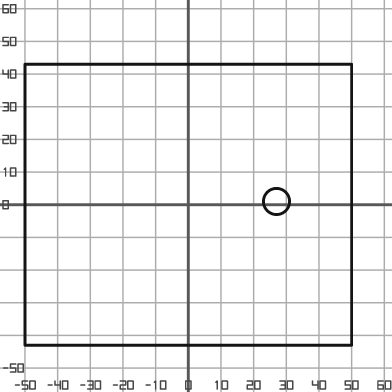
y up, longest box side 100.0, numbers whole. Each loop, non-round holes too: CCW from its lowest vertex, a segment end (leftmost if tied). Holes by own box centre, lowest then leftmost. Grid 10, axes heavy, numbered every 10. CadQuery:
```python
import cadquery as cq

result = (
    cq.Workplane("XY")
    .moveTo(-50.0, -43.0)
    .lineTo(50.0, -43.0)
    .lineTo(50.0, 43.0)
    .lineTo(-50.0, 43.0)
    .close()
    .moveTo(27.0, 1.0)
    .circle(4.0)
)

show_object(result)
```